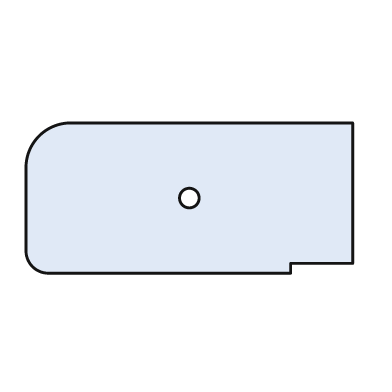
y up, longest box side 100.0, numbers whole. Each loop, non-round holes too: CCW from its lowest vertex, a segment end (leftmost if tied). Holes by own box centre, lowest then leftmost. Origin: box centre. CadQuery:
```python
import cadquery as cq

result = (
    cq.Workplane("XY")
    .moveTo(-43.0, -23.0)
    .lineTo(31.0, -23.0)
    .lineTo(31.0, -20.0)
    .lineTo(50.0, -20.0)
    .lineTo(50.0, 23.0)
    .lineTo(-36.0, 23.0)
    .threePointArc((-46.0, 19.0), (-50.0, 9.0))
    .lineTo(-50.0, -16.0)
    .threePointArc((-48.0, -21.0), (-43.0, -23.0))
    .close()
    .moveTo(0.0, 0.0)
    .circle(3.0)
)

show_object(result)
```